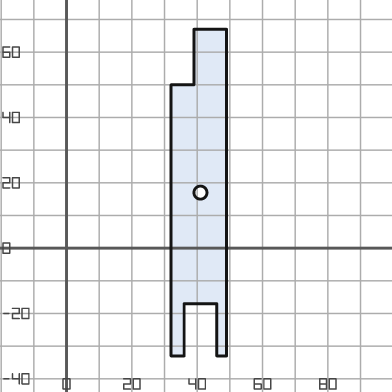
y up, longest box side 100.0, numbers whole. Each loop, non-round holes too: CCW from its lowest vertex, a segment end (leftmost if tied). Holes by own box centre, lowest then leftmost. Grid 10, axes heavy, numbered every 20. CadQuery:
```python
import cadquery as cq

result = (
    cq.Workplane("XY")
    .moveTo(32.0, -33.0)
    .lineTo(36.0, -33.0)
    .lineTo(36.0, -17.0)
    .lineTo(46.0, -17.0)
    .lineTo(46.0, -33.0)
    .lineTo(49.0, -33.0)
    .lineTo(49.0, 67.0)
    .lineTo(39.0, 67.0)
    .lineTo(39.0, 50.0)
    .lineTo(32.0, 50.0)
    .close()
    .moveTo(41.0, 17.0)
    .circle(2.0)
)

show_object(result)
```